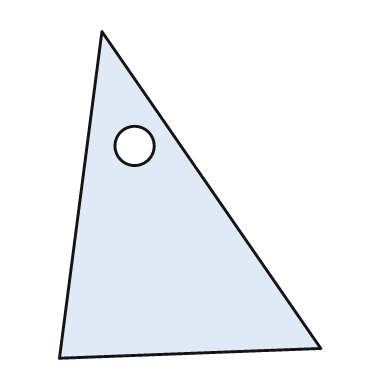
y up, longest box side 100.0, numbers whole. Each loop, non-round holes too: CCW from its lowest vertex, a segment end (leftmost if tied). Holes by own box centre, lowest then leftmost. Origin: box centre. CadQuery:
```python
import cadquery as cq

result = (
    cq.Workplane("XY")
    .moveTo(-40.0, -50.0)
    .lineTo(40.0, -47.0)
    .lineTo(-27.0, 50.0)
    .close()
    .moveTo(-17.0, 15.0)
    .circle(6.0)
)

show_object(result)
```